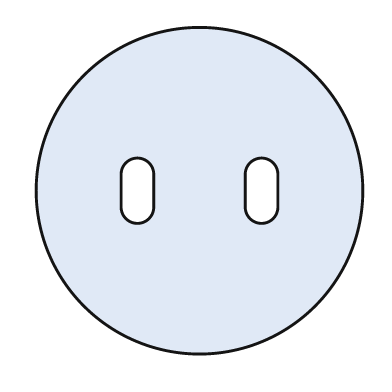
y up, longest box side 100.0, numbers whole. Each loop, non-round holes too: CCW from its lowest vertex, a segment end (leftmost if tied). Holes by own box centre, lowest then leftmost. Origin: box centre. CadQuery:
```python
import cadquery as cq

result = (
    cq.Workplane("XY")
    .moveTo(0.0, 0.0)
    .circle(50.0)
    .moveTo(-24.0, -5.0)
    .threePointArc((-19.0, -10.0), (-14.0, -5.0))
    .lineTo(-14.0, 5.0)
    .threePointArc((-19.0, 10.0), (-24.0, 5.0))
    .close()
    .moveTo(14.0, -5.0)
    .threePointArc((19.0, -10.0), (24.0, -5.0))
    .lineTo(24.0, 5.0)
    .threePointArc((19.0, 10.0), (14.0, 5.0))
    .close()
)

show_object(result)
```